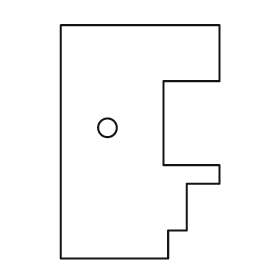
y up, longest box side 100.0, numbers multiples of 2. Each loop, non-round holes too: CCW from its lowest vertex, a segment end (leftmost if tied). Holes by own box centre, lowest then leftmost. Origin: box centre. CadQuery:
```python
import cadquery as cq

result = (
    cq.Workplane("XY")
    .moveTo(-34.0, -50.0)
    .lineTo(12.0, -50.0)
    .lineTo(12.0, -38.0)
    .lineTo(20.0, -38.0)
    .lineTo(20.0, -18.0)
    .lineTo(34.0, -18.0)
    .lineTo(34.0, -10.0)
    .lineTo(10.0, -10.0)
    .lineTo(10.0, 26.0)
    .lineTo(34.0, 26.0)
    .lineTo(34.0, 50.0)
    .lineTo(-34.0, 50.0)
    .close()
    .moveTo(-14.0, 6.0)
    .circle(4.0)
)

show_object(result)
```